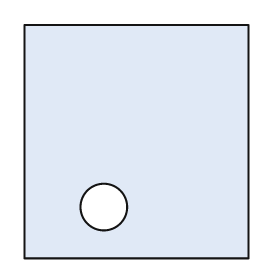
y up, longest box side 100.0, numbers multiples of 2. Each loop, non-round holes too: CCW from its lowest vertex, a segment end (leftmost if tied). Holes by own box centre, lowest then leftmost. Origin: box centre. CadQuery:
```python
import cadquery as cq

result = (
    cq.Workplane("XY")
    .moveTo(-48.0, -50.0)
    .lineTo(48.0, -50.0)
    .lineTo(48.0, 50.0)
    .lineTo(-48.0, 50.0)
    .close()
    .moveTo(-14.0, -28.0)
    .circle(10.0)
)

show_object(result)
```